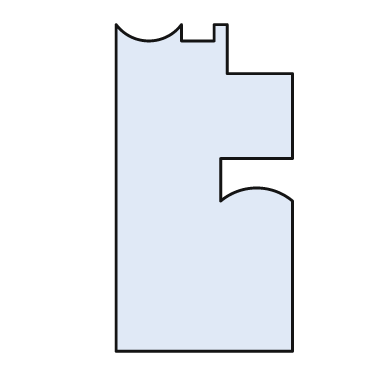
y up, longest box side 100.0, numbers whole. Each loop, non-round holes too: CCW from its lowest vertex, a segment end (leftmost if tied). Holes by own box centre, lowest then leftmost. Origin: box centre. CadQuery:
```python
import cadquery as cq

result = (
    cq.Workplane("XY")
    .moveTo(-27.0, -50.0)
    .lineTo(27.0, -50.0)
    .lineTo(27.0, -4.0)
    .threePointArc((16.0, 0.0), (5.0, -4.0))
    .lineTo(5.0, 9.0)
    .lineTo(27.0, 9.0)
    .lineTo(27.0, 35.0)
    .lineTo(7.0, 35.0)
    .lineTo(7.0, 50.0)
    .lineTo(3.0, 50.0)
    .lineTo(3.0, 45.0)
    .lineTo(-7.0, 45.0)
    .lineTo(-7.0, 50.0)
    .threePointArc((-17.0, 45.0), (-27.0, 50.0))
    .close()
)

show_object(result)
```